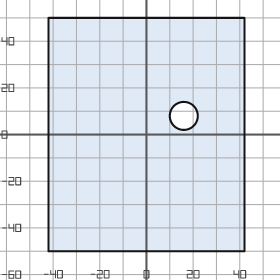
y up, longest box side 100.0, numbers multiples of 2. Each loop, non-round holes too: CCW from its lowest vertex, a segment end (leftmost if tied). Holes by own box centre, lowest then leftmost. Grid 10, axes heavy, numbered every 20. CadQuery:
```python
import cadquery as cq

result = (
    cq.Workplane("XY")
    .moveTo(-42.0, -50.0)
    .lineTo(42.0, -50.0)
    .lineTo(42.0, 50.0)
    .lineTo(-42.0, 50.0)
    .close()
    .moveTo(16.0, 8.0)
    .circle(6.0)
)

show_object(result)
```